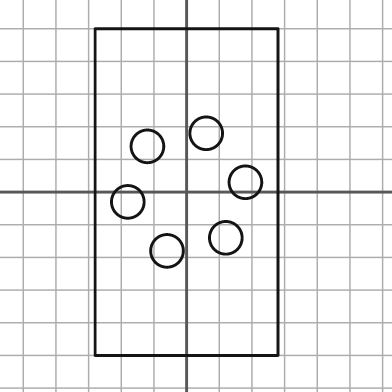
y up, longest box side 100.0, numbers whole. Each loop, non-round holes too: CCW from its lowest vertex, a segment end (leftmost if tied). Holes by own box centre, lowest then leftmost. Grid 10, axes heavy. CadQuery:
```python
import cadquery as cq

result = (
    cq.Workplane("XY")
    .moveTo(-28.0, -50.0)
    .lineTo(28.0, -50.0)
    .lineTo(28.0, 50.0)
    .lineTo(-28.0, 50.0)
    .close()
    .moveTo(-6.0, -18.0)
    .circle(5.0)
    .moveTo(12.0, -14.0)
    .circle(5.0)
    .moveTo(-18.0, -3.0)
    .circle(5.0)
    .moveTo(18.0, 3.0)
    .circle(5.0)
    .moveTo(-12.0, 14.0)
    .circle(5.0)
    .moveTo(6.0, 18.0)
    .circle(5.0)
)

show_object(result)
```